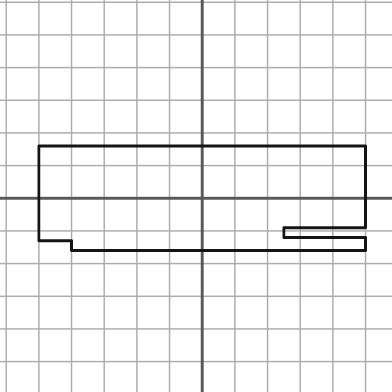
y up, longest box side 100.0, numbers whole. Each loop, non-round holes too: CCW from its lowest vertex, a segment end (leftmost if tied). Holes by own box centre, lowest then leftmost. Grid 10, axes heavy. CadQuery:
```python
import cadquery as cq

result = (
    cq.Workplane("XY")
    .moveTo(-40.0, -16.0)
    .lineTo(50.0, -16.0)
    .lineTo(50.0, -12.0)
    .lineTo(25.0, -12.0)
    .lineTo(25.0, -9.0)
    .lineTo(50.0, -9.0)
    .lineTo(50.0, 16.0)
    .lineTo(-50.0, 16.0)
    .lineTo(-50.0, -13.0)
    .lineTo(-40.0, -13.0)
    .close()
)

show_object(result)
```